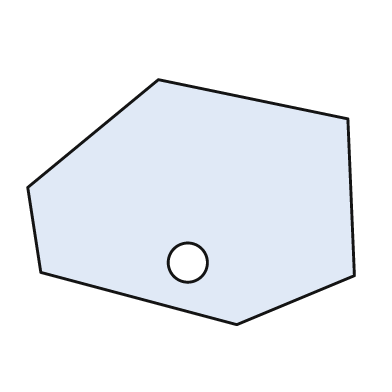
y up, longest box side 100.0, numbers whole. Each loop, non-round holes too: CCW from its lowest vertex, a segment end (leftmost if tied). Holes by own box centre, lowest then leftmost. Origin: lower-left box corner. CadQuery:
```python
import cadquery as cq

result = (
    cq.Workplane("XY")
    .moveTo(64.0, 0.0)
    .lineTo(100.0, 15.0)
    .lineTo(98.0, 63.0)
    .lineTo(40.0, 75.0)
    .lineTo(0.0, 42.0)
    .lineTo(4.0, 16.0)
    .close()
    .moveTo(49.0, 19.0)
    .circle(6.0)
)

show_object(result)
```